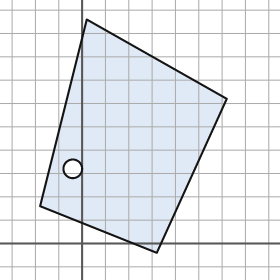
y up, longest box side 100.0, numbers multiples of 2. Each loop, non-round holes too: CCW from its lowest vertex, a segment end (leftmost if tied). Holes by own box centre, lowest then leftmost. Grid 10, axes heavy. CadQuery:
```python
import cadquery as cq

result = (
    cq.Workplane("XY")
    .moveTo(32.0, -4.0)
    .lineTo(62.0, 62.0)
    .lineTo(2.0, 96.0)
    .lineTo(-18.0, 16.0)
    .close()
    .moveTo(-4.0, 32.0)
    .circle(4.0)
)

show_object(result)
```